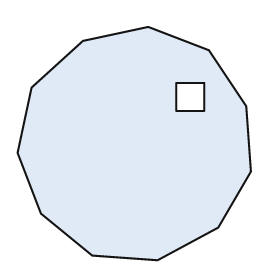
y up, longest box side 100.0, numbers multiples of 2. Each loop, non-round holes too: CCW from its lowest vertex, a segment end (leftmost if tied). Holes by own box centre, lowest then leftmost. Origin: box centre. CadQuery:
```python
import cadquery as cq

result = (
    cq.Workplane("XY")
    .moveTo(10.0, -50.0)
    .lineTo(36.0, -36.0)
    .lineTo(50.0, -12.0)
    .lineTo(48.0, 16.0)
    .lineTo(32.0, 40.0)
    .lineTo(6.0, 50.0)
    .lineTo(-22.0, 44.0)
    .lineTo(-44.0, 24.0)
    .lineTo(-50.0, -4.0)
    .lineTo(-40.0, -30.0)
    .lineTo(-18.0, -48.0)
    .close()
    .moveTo(18.0, 14.0)
    .lineTo(30.0, 14.0)
    .lineTo(30.0, 26.0)
    .lineTo(18.0, 26.0)
    .close()
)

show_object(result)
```